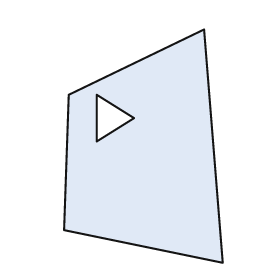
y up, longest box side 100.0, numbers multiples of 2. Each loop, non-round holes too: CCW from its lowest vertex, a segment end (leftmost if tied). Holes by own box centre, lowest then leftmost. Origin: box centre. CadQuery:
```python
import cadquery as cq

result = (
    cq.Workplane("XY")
    .moveTo(34.0, -50.0)
    .lineTo(26.0, 50.0)
    .lineTo(-32.0, 22.0)
    .lineTo(-34.0, -36.0)
    .close()
    .moveTo(-20.0, 2.0)
    .lineTo(-4.0, 12.0)
    .lineTo(-20.0, 22.0)
    .close()
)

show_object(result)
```